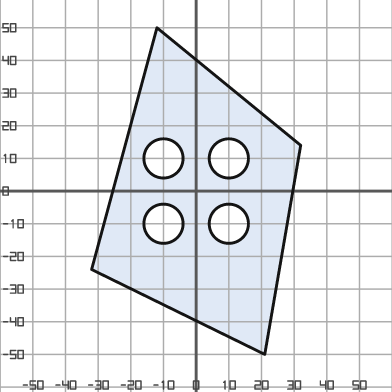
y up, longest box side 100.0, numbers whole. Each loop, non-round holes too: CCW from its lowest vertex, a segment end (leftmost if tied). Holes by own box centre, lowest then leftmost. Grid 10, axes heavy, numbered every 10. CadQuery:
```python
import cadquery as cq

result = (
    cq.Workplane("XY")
    .moveTo(21.0, -50.0)
    .lineTo(32.0, 14.0)
    .lineTo(-12.0, 50.0)
    .lineTo(-32.0, -24.0)
    .close()
    .moveTo(-10.0, -10.0)
    .circle(6.0)
    .moveTo(10.0, -10.0)
    .circle(6.0)
    .moveTo(-10.0, 10.0)
    .circle(6.0)
    .moveTo(10.0, 10.0)
    .circle(6.0)
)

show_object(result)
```